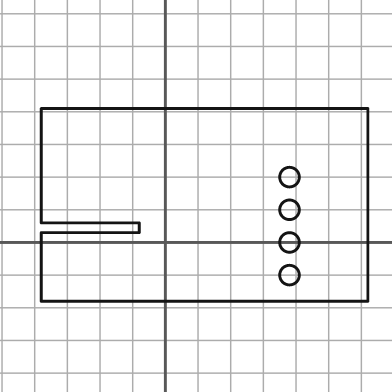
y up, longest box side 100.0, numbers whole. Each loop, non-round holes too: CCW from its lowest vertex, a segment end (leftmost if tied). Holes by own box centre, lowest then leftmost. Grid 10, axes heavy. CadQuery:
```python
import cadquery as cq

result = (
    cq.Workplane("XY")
    .moveTo(-38.0, -18.0)
    .lineTo(62.0, -18.0)
    .lineTo(62.0, 41.0)
    .lineTo(-38.0, 41.0)
    .lineTo(-38.0, 6.0)
    .lineTo(-8.0, 6.0)
    .lineTo(-8.0, 3.0)
    .lineTo(-38.0, 3.0)
    .close()
    .moveTo(38.0, -10.0)
    .circle(3.0)
    .moveTo(38.0, 0.0)
    .circle(3.0)
    .moveTo(38.0, 10.0)
    .circle(3.0)
    .moveTo(38.0, 20.0)
    .circle(3.0)
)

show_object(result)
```